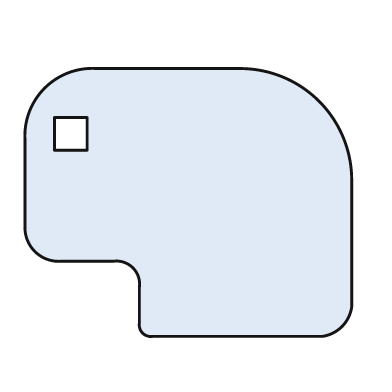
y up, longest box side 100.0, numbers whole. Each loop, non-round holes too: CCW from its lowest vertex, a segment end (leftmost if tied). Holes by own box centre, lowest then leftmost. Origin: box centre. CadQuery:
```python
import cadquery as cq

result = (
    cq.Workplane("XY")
    .moveTo(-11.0, -41.0)
    .lineTo(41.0, -41.0)
    .threePointArc((47.0, -38.0), (50.0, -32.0))
    .lineTo(50.0, 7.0)
    .threePointArc((40.0, 31.0), (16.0, 41.0))
    .lineTo(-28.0, 41.0)
    .threePointArc((-44.0, 35.0), (-50.0, 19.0))
    .lineTo(-50.0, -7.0)
    .threePointArc((-47.0, -15.0), (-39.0, -18.0))
    .lineTo(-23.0, -18.0)
    .threePointArc((-17.0, -20.0), (-15.0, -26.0))
    .lineTo(-15.0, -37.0)
    .threePointArc((-14.0, -40.0), (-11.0, -41.0))
    .close()
    .moveTo(-41.0, 16.0)
    .lineTo(-31.0, 16.0)
    .lineTo(-31.0, 26.0)
    .lineTo(-41.0, 26.0)
    .close()
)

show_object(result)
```